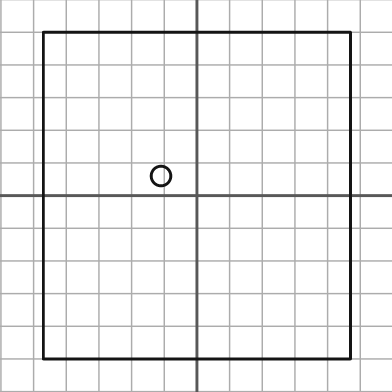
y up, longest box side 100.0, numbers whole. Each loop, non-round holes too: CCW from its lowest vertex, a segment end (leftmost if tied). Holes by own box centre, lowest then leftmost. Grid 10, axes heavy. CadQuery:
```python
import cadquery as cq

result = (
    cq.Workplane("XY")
    .moveTo(-47.0, -50.0)
    .lineTo(47.0, -50.0)
    .lineTo(47.0, 50.0)
    .lineTo(-47.0, 50.0)
    .close()
    .moveTo(-11.0, 6.0)
    .circle(3.0)
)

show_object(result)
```